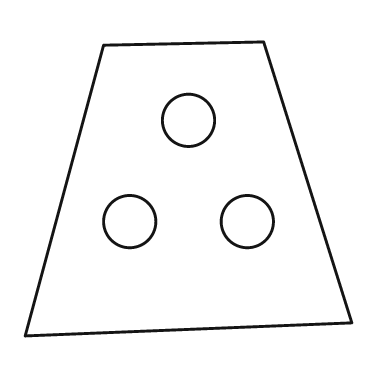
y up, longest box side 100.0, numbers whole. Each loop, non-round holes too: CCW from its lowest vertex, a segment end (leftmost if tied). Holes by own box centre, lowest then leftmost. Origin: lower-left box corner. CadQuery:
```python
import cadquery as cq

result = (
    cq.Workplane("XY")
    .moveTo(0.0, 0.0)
    .lineTo(100.0, 4.0)
    .lineTo(73.0, 90.0)
    .lineTo(24.0, 89.0)
    .close()
    .moveTo(32.0, 35.0)
    .circle(8.0)
    .moveTo(68.0, 35.0)
    .circle(8.0)
    .moveTo(50.0, 66.0)
    .circle(8.0)
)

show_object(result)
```